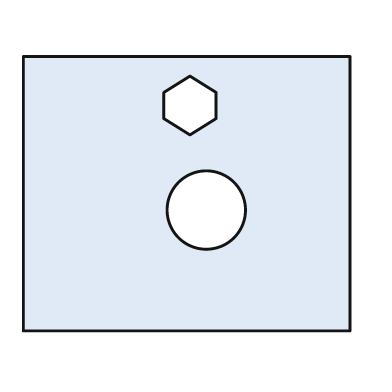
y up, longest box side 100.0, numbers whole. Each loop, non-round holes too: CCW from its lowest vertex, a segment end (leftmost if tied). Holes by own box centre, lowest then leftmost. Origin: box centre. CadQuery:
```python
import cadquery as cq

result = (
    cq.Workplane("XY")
    .moveTo(-50.0, -42.0)
    .lineTo(50.0, -42.0)
    .lineTo(50.0, 42.0)
    .lineTo(-50.0, 42.0)
    .close()
    .moveTo(6.0, -5.0)
    .circle(12.0)
    .moveTo(1.0, 18.0)
    .lineTo(9.0, 23.0)
    .lineTo(9.0, 31.0)
    .lineTo(1.0, 36.0)
    .lineTo(-7.0, 31.0)
    .lineTo(-7.0, 23.0)
    .close()
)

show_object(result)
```